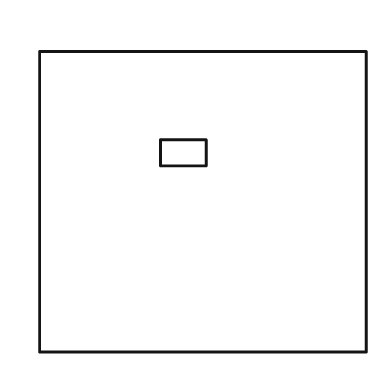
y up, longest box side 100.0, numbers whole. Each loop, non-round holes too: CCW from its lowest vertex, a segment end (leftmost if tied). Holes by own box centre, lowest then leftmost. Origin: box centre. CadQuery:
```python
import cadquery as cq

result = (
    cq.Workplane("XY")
    .moveTo(-50.0, -46.0)
    .lineTo(50.0, -46.0)
    .lineTo(50.0, 46.0)
    .lineTo(-50.0, 46.0)
    .close()
    .moveTo(-13.0, 11.0)
    .lineTo(1.0, 11.0)
    .lineTo(1.0, 19.0)
    .lineTo(-13.0, 19.0)
    .close()
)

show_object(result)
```